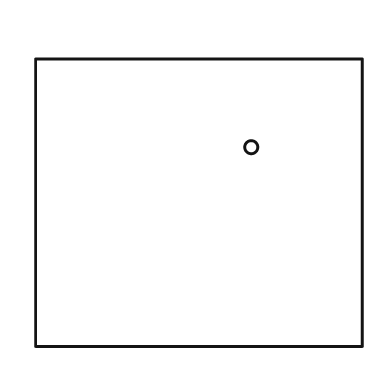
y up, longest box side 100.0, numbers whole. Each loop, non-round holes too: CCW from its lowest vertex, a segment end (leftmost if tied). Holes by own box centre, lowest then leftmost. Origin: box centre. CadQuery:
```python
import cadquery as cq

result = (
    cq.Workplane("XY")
    .moveTo(-50.0, -44.0)
    .lineTo(50.0, -44.0)
    .lineTo(50.0, 44.0)
    .lineTo(-50.0, 44.0)
    .close()
    .moveTo(16.0, 17.0)
    .circle(2.0)
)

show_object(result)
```